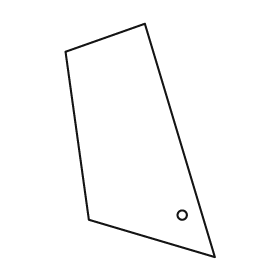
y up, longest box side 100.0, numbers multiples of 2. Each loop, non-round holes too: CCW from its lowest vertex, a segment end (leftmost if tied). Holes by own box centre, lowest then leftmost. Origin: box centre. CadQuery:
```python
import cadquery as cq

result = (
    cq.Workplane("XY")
    .moveTo(32.0, -50.0)
    .lineTo(2.0, 50.0)
    .lineTo(-32.0, 38.0)
    .lineTo(-22.0, -34.0)
    .close()
    .moveTo(18.0, -32.0)
    .circle(2.0)
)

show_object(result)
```